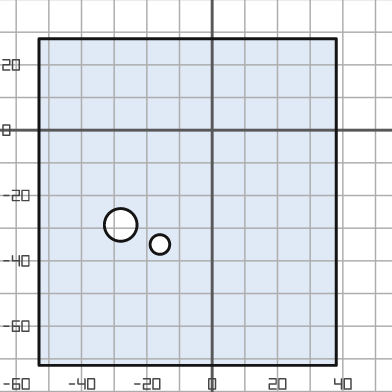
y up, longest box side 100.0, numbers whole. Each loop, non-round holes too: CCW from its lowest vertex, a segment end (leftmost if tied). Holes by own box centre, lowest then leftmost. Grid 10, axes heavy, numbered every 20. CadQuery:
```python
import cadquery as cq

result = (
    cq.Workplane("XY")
    .moveTo(-53.0, -72.0)
    .lineTo(38.0, -72.0)
    .lineTo(38.0, 28.0)
    .lineTo(-53.0, 28.0)
    .close()
    .moveTo(-16.0, -35.0)
    .circle(3.0)
    .moveTo(-28.0, -29.0)
    .circle(5.0)
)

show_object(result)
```